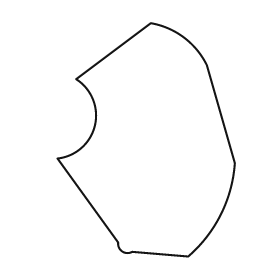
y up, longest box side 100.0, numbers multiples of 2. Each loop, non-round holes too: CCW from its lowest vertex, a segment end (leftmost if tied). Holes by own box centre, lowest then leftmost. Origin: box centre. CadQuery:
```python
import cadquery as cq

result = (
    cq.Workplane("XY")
    .moveTo(18.0, -50.0)
    .threePointArc((32.0, -32.0), (38.0, -10.0))
    .lineTo(26.0, 32.0)
    .threePointArc((16.0, 44.0), (2.0, 50.0))
    .lineTo(-30.0, 26.0)
    .threePointArc((-22.0, 6.0), (-38.0, -8.0))
    .lineTo(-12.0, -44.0)
    .threePointArc((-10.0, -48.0), (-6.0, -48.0))
    .close()
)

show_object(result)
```